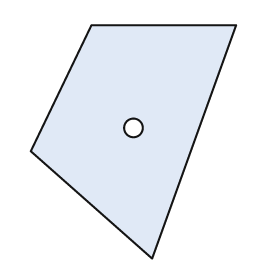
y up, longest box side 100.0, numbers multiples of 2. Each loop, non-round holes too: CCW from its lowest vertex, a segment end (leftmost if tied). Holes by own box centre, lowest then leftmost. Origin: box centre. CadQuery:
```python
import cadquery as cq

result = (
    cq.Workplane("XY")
    .moveTo(8.0, -50.0)
    .lineTo(44.0, 50.0)
    .lineTo(-18.0, 50.0)
    .lineTo(-44.0, -4.0)
    .close()
    .moveTo(0.0, 6.0)
    .circle(4.0)
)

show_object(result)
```